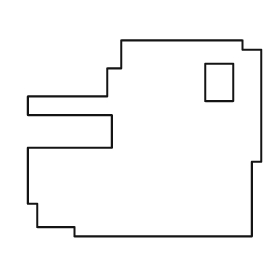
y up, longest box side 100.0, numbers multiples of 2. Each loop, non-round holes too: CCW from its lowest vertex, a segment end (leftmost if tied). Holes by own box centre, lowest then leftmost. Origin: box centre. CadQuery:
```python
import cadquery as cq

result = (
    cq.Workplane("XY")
    .moveTo(-30.0, -42.0)
    .lineTo(46.0, -42.0)
    .lineTo(46.0, -10.0)
    .lineTo(50.0, -10.0)
    .lineTo(50.0, 38.0)
    .lineTo(42.0, 38.0)
    .lineTo(42.0, 42.0)
    .lineTo(-10.0, 42.0)
    .lineTo(-10.0, 30.0)
    .lineTo(-16.0, 30.0)
    .lineTo(-16.0, 18.0)
    .lineTo(-50.0, 18.0)
    .lineTo(-50.0, 10.0)
    .lineTo(-14.0, 10.0)
    .lineTo(-14.0, -4.0)
    .lineTo(-50.0, -4.0)
    .lineTo(-50.0, -28.0)
    .lineTo(-46.0, -28.0)
    .lineTo(-46.0, -38.0)
    .lineTo(-30.0, -38.0)
    .close()
    .moveTo(26.0, 16.0)
    .lineTo(38.0, 16.0)
    .lineTo(38.0, 32.0)
    .lineTo(26.0, 32.0)
    .close()
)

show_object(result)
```